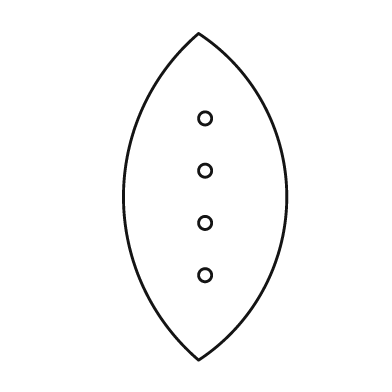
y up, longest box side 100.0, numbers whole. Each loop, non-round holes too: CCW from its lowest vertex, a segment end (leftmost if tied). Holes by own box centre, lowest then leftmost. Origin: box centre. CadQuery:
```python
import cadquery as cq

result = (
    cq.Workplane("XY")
    .moveTo(-2.0, -50.0)
    .threePointArc((25.0, 0.0), (-2.0, 50.0))
    .threePointArc((-25.0, 0.0), (-2.0, -50.0))
    .close()
    .moveTo(0.0, -24.0)
    .circle(2.0)
    .moveTo(0.0, -8.0)
    .circle(2.0)
    .moveTo(0.0, 8.0)
    .circle(2.0)
    .moveTo(0.0, 24.0)
    .circle(2.0)
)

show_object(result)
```